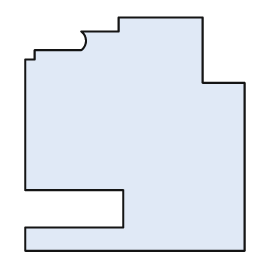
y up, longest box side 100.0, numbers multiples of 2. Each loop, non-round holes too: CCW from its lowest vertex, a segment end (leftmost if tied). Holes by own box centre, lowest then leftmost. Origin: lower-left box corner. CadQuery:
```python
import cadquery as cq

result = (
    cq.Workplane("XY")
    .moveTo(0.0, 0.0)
    .lineTo(94.0, 0.0)
    .lineTo(94.0, 72.0)
    .lineTo(76.0, 72.0)
    .lineTo(76.0, 100.0)
    .lineTo(40.0, 100.0)
    .lineTo(40.0, 94.0)
    .lineTo(24.0, 94.0)
    .threePointArc((26.0, 90.0), (24.0, 86.0))
    .lineTo(4.0, 86.0)
    .lineTo(4.0, 82.0)
    .lineTo(0.0, 82.0)
    .lineTo(0.0, 26.0)
    .lineTo(42.0, 26.0)
    .lineTo(42.0, 10.0)
    .lineTo(0.0, 10.0)
    .close()
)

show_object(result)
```